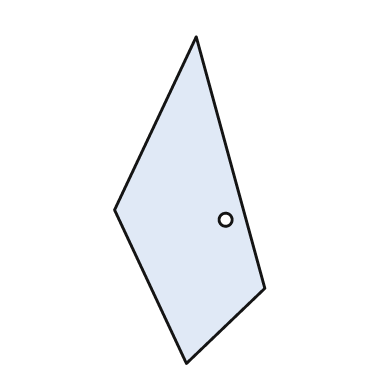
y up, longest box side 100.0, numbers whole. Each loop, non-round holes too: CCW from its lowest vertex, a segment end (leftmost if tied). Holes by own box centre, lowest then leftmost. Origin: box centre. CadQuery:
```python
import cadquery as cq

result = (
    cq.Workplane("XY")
    .moveTo(-1.0, -50.0)
    .lineTo(23.0, -27.0)
    .lineTo(2.0, 50.0)
    .lineTo(-23.0, -3.0)
    .close()
    .moveTo(11.0, -6.0)
    .circle(2.0)
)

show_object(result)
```